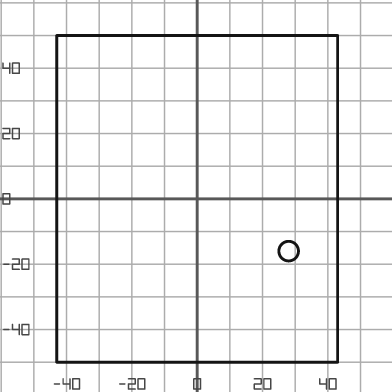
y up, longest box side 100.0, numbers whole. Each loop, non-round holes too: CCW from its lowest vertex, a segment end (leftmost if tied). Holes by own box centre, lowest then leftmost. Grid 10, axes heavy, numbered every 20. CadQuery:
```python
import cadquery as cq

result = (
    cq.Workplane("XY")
    .moveTo(-43.0, -50.0)
    .lineTo(43.0, -50.0)
    .lineTo(43.0, 50.0)
    .lineTo(-43.0, 50.0)
    .close()
    .moveTo(28.0, -16.0)
    .circle(3.0)
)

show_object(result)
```